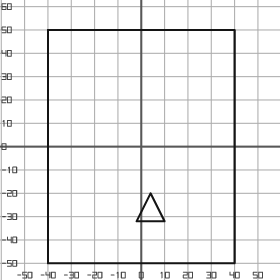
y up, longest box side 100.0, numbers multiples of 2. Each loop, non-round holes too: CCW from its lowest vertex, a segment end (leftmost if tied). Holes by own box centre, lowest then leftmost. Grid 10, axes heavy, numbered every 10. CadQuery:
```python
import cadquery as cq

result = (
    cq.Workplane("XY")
    .moveTo(-40.0, -50.0)
    .lineTo(40.0, -50.0)
    .lineTo(40.0, 50.0)
    .lineTo(-40.0, 50.0)
    .close()
    .moveTo(-2.0, -32.0)
    .lineTo(10.0, -32.0)
    .lineTo(4.0, -20.0)
    .close()
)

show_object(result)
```